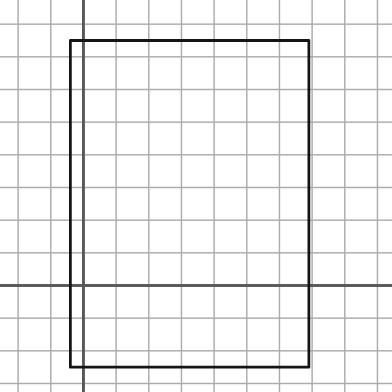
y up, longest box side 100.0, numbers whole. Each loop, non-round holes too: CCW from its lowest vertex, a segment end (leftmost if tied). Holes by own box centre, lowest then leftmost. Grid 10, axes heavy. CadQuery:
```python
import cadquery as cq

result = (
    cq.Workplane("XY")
    .moveTo(-4.0, -25.0)
    .lineTo(69.0, -25.0)
    .lineTo(69.0, 75.0)
    .lineTo(-4.0, 75.0)
    .close()
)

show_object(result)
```